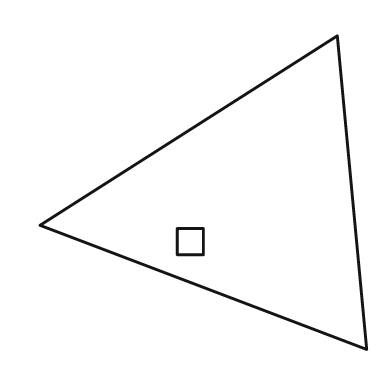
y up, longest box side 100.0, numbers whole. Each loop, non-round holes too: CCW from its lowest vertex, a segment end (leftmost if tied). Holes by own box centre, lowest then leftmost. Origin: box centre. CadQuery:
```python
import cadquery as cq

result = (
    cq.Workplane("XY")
    .moveTo(50.0, -48.0)
    .lineTo(41.0, 48.0)
    .lineTo(-50.0, -10.0)
    .close()
    .moveTo(-8.0, -19.0)
    .lineTo(0.0, -19.0)
    .lineTo(0.0, -11.0)
    .lineTo(-8.0, -11.0)
    .close()
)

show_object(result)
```